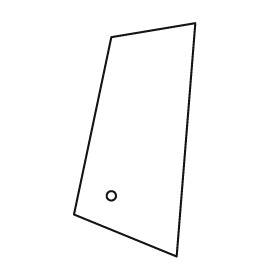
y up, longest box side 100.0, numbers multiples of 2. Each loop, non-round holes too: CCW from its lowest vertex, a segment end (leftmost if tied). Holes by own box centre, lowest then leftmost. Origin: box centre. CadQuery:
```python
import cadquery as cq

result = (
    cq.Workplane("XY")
    .moveTo(18.0, -50.0)
    .lineTo(26.0, 50.0)
    .lineTo(-10.0, 44.0)
    .lineTo(-26.0, -32.0)
    .close()
    .moveTo(-10.0, -24.0)
    .circle(2.0)
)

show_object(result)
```